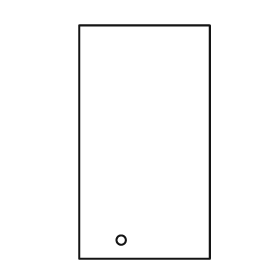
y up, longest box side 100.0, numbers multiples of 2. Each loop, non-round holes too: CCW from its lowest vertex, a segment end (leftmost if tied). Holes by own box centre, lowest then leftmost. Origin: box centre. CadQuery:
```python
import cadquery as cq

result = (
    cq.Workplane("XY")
    .moveTo(-28.0, -50.0)
    .lineTo(28.0, -50.0)
    .lineTo(28.0, 50.0)
    .lineTo(-28.0, 50.0)
    .close()
    .moveTo(-10.0, -42.0)
    .circle(2.0)
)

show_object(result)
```